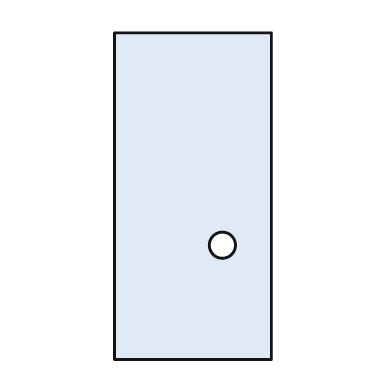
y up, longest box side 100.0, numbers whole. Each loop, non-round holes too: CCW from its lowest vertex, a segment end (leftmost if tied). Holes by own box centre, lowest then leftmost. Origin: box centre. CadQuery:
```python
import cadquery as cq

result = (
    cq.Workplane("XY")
    .moveTo(-24.0, -50.0)
    .lineTo(24.0, -50.0)
    .lineTo(24.0, 50.0)
    .lineTo(-24.0, 50.0)
    .close()
    .moveTo(9.0, -15.0)
    .circle(4.0)
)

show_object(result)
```